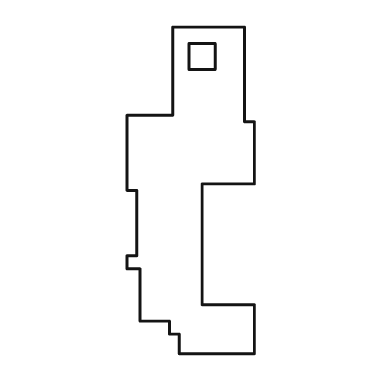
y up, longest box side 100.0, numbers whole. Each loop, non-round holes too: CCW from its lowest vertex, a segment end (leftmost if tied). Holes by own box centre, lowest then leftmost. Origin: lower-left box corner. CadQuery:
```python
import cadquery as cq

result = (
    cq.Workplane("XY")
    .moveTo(16.0, 0.0)
    .lineTo(39.0, 0.0)
    .lineTo(39.0, 15.0)
    .lineTo(23.0, 15.0)
    .lineTo(23.0, 52.0)
    .lineTo(39.0, 52.0)
    .lineTo(39.0, 71.0)
    .lineTo(36.0, 71.0)
    .lineTo(36.0, 100.0)
    .lineTo(14.0, 100.0)
    .lineTo(14.0, 73.0)
    .lineTo(0.0, 73.0)
    .lineTo(0.0, 50.0)
    .lineTo(3.0, 50.0)
    .lineTo(3.0, 30.0)
    .lineTo(0.0, 30.0)
    .lineTo(0.0, 26.0)
    .lineTo(4.0, 26.0)
    .lineTo(4.0, 10.0)
    .lineTo(13.0, 10.0)
    .lineTo(13.0, 6.0)
    .lineTo(16.0, 6.0)
    .close()
    .moveTo(19.0, 87.0)
    .lineTo(27.0, 87.0)
    .lineTo(27.0, 95.0)
    .lineTo(19.0, 95.0)
    .close()
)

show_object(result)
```